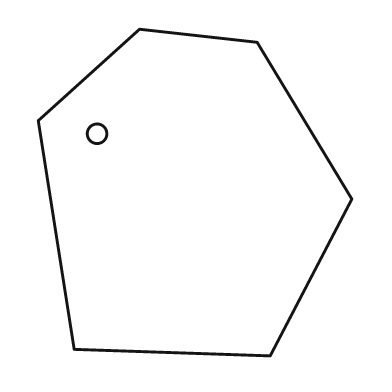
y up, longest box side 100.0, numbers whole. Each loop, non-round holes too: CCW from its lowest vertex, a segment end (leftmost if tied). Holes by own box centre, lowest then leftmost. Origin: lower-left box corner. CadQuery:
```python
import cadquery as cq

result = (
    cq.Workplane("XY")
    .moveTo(71.0, 0.0)
    .lineTo(96.0, 48.0)
    .lineTo(67.0, 96.0)
    .lineTo(31.0, 100.0)
    .lineTo(0.0, 72.0)
    .lineTo(11.0, 2.0)
    .close()
    .moveTo(18.0, 68.0)
    .circle(3.0)
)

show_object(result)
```